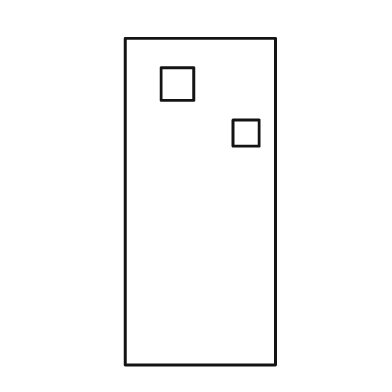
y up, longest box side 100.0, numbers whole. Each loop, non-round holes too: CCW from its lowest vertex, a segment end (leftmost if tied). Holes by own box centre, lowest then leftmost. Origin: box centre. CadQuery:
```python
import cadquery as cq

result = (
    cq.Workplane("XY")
    .moveTo(-23.0, -50.0)
    .lineTo(23.0, -50.0)
    .lineTo(23.0, 50.0)
    .lineTo(-23.0, 50.0)
    .close()
    .moveTo(10.0, 17.0)
    .lineTo(18.0, 17.0)
    .lineTo(18.0, 25.0)
    .lineTo(10.0, 25.0)
    .close()
    .moveTo(-12.0, 31.0)
    .lineTo(-2.0, 31.0)
    .lineTo(-2.0, 41.0)
    .lineTo(-12.0, 41.0)
    .close()
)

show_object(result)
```